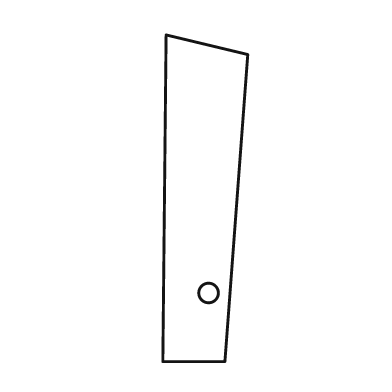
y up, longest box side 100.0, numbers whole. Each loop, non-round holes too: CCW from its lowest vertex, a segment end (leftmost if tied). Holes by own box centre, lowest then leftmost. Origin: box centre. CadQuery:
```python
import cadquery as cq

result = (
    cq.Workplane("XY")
    .moveTo(-13.0, -50.0)
    .lineTo(6.0, -50.0)
    .lineTo(13.0, 44.0)
    .lineTo(-12.0, 50.0)
    .close()
    .moveTo(1.0, -29.0)
    .circle(3.0)
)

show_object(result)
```